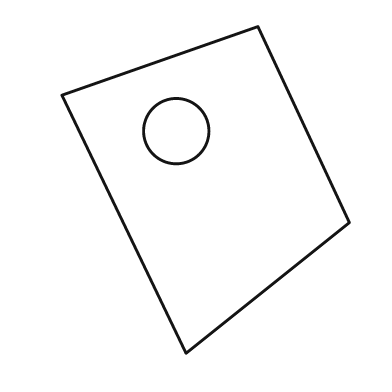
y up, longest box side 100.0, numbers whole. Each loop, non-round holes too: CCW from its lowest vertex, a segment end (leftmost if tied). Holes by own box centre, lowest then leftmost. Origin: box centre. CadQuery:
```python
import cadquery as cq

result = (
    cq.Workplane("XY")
    .moveTo(-6.0, -50.0)
    .lineTo(44.0, -10.0)
    .lineTo(16.0, 50.0)
    .lineTo(-44.0, 29.0)
    .close()
    .moveTo(-9.0, 18.0)
    .circle(10.0)
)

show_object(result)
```